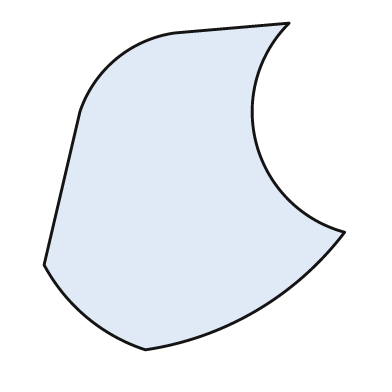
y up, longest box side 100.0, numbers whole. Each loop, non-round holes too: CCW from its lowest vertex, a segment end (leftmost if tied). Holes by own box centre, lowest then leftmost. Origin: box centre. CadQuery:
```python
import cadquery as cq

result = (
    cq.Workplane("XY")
    .moveTo(-15.0, -50.0)
    .threePointArc((19.0, -38.0), (46.0, -14.0))
    .threePointArc((19.0, 13.0), (29.0, 50.0))
    .lineTo(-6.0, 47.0)
    .threePointArc((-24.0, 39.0), (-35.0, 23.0))
    .lineTo(-46.0, -24.0)
    .threePointArc((-33.0, -40.0), (-15.0, -50.0))
    .close()
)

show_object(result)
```